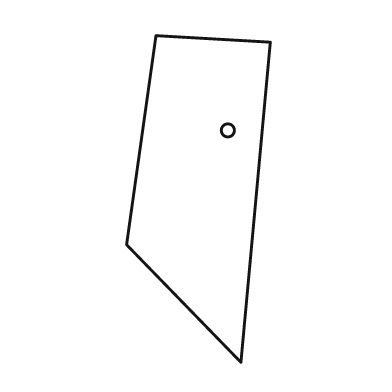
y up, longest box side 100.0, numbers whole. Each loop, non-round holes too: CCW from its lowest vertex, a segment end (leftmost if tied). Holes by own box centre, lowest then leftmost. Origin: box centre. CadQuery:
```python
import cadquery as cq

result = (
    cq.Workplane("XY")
    .moveTo(13.0, -50.0)
    .lineTo(22.0, 48.0)
    .lineTo(-13.0, 50.0)
    .lineTo(-22.0, -14.0)
    .close()
    .moveTo(9.0, 21.0)
    .circle(2.0)
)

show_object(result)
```